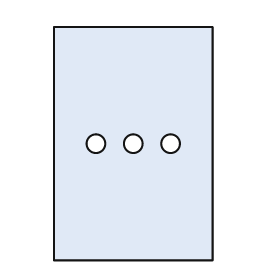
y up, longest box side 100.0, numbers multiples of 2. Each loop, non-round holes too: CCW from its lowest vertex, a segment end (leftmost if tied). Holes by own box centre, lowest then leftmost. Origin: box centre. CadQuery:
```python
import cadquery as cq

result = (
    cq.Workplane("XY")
    .moveTo(-34.0, -50.0)
    .lineTo(34.0, -50.0)
    .lineTo(34.0, 50.0)
    .lineTo(-34.0, 50.0)
    .close()
    .moveTo(-16.0, 0.0)
    .circle(4.0)
    .moveTo(0.0, 0.0)
    .circle(4.0)
    .moveTo(16.0, 0.0)
    .circle(4.0)
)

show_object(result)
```